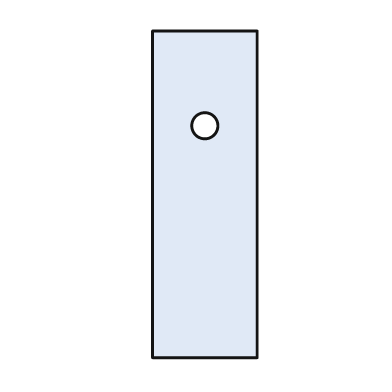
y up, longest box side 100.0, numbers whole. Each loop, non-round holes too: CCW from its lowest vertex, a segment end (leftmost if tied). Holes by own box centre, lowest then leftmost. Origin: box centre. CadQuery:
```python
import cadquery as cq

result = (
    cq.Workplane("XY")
    .moveTo(-16.0, -50.0)
    .lineTo(16.0, -50.0)
    .lineTo(16.0, 50.0)
    .lineTo(-16.0, 50.0)
    .close()
    .moveTo(0.0, 21.0)
    .circle(4.0)
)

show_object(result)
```